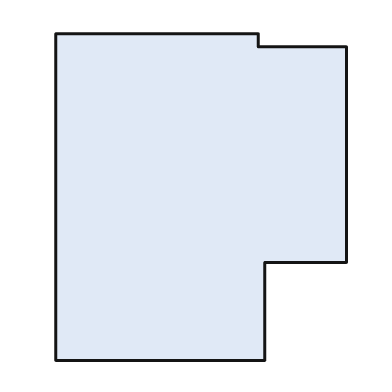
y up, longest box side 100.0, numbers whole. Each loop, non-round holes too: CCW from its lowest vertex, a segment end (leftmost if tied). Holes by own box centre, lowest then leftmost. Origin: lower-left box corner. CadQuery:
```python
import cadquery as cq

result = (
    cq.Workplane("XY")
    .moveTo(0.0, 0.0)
    .lineTo(64.0, 0.0)
    .lineTo(64.0, 30.0)
    .lineTo(89.0, 30.0)
    .lineTo(89.0, 96.0)
    .lineTo(62.0, 96.0)
    .lineTo(62.0, 100.0)
    .lineTo(0.0, 100.0)
    .close()
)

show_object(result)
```